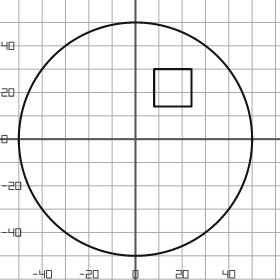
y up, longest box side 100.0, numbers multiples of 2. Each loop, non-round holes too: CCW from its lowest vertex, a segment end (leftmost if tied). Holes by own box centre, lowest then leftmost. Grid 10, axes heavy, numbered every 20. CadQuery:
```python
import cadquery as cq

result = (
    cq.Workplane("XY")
    .moveTo(0.0, 0.0)
    .circle(50.0)
    .moveTo(8.0, 14.0)
    .lineTo(24.0, 14.0)
    .lineTo(24.0, 30.0)
    .lineTo(8.0, 30.0)
    .close()
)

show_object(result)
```